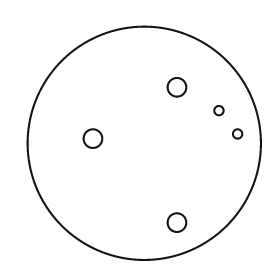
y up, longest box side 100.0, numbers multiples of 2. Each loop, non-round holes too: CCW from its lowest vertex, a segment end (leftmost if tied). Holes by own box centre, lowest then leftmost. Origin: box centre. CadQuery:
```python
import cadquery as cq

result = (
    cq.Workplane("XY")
    .moveTo(0.0, 0.0)
    .circle(50.0)
    .moveTo(14.0, -34.0)
    .circle(4.0)
    .moveTo(-22.0, 2.0)
    .circle(4.0)
    .moveTo(40.0, 4.0)
    .circle(2.0)
    .moveTo(32.0, 14.0)
    .circle(2.0)
    .moveTo(14.0, 24.0)
    .circle(4.0)
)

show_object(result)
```